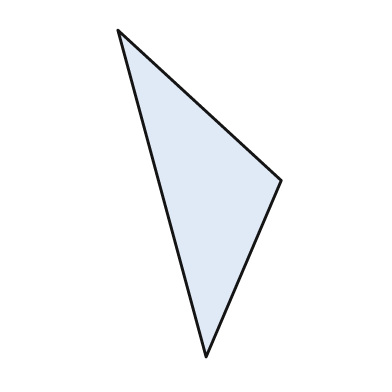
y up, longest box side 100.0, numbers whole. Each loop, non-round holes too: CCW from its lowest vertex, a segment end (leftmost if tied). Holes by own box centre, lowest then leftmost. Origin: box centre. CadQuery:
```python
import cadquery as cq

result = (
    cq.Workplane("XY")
    .moveTo(2.0, -50.0)
    .lineTo(25.0, 4.0)
    .lineTo(-25.0, 50.0)
    .close()
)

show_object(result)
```